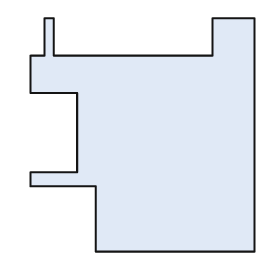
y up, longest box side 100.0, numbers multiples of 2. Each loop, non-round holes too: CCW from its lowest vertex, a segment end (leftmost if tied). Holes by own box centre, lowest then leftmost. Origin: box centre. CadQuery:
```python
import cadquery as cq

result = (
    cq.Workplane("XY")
    .moveTo(-20.0, -50.0)
    .lineTo(48.0, -50.0)
    .lineTo(48.0, 50.0)
    .lineTo(30.0, 50.0)
    .lineTo(30.0, 34.0)
    .lineTo(-38.0, 34.0)
    .lineTo(-38.0, 50.0)
    .lineTo(-42.0, 50.0)
    .lineTo(-42.0, 34.0)
    .lineTo(-48.0, 34.0)
    .lineTo(-48.0, 18.0)
    .lineTo(-28.0, 18.0)
    .lineTo(-28.0, -16.0)
    .lineTo(-48.0, -16.0)
    .lineTo(-48.0, -22.0)
    .lineTo(-20.0, -22.0)
    .close()
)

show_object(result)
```